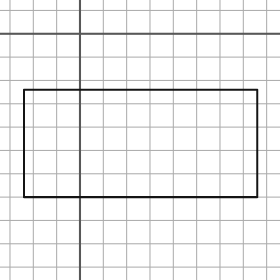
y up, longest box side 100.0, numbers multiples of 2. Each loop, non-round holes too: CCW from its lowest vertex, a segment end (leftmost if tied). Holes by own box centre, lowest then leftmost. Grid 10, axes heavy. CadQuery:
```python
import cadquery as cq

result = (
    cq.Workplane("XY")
    .moveTo(-24.0, -70.0)
    .lineTo(76.0, -70.0)
    .lineTo(76.0, -24.0)
    .lineTo(-24.0, -24.0)
    .close()
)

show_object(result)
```